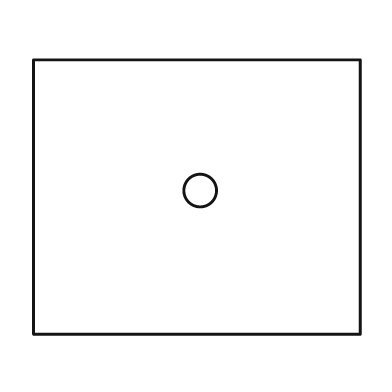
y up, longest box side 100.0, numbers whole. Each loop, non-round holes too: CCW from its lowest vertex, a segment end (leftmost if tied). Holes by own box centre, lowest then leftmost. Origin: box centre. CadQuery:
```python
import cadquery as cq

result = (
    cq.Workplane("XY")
    .moveTo(-50.0, -42.0)
    .lineTo(50.0, -42.0)
    .lineTo(50.0, 42.0)
    .lineTo(-50.0, 42.0)
    .close()
    .moveTo(1.0, 2.0)
    .circle(5.0)
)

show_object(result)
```